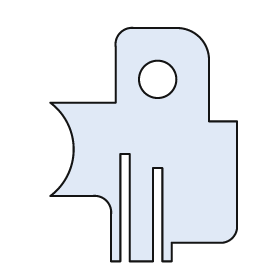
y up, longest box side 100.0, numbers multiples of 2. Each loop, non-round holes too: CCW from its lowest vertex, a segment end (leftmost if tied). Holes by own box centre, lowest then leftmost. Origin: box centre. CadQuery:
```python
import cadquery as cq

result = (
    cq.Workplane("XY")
    .moveTo(-14.0, -50.0)
    .lineTo(-10.0, -50.0)
    .lineTo(-10.0, -4.0)
    .lineTo(-6.0, -4.0)
    .lineTo(-6.0, -50.0)
    .lineTo(4.0, -50.0)
    .lineTo(4.0, -10.0)
    .lineTo(8.0, -10.0)
    .lineTo(8.0, -50.0)
    .lineTo(12.0, -50.0)
    .lineTo(12.0, -42.0)
    .lineTo(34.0, -42.0)
    .threePointArc((38.0, -40.0), (40.0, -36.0))
    .lineTo(40.0, 10.0)
    .lineTo(28.0, 10.0)
    .lineTo(28.0, 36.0)
    .threePointArc((24.0, 46.0), (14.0, 50.0))
    .lineTo(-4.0, 50.0)
    .threePointArc((-10.0, 48.0), (-12.0, 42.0))
    .lineTo(-12.0, 18.0)
    .lineTo(-40.0, 18.0)
    .threePointArc((-30.0, -2.0), (-40.0, -22.0))
    .lineTo(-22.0, -22.0)
    .threePointArc((-16.0, -24.0), (-14.0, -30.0))
    .close()
    .moveTo(6.0, 28.0)
    .circle(8.0)
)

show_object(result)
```